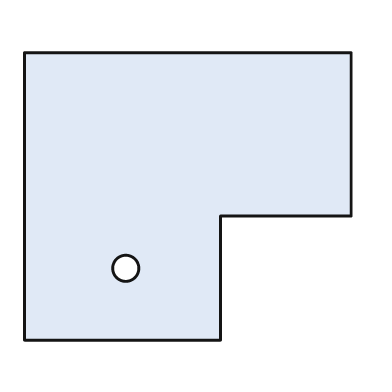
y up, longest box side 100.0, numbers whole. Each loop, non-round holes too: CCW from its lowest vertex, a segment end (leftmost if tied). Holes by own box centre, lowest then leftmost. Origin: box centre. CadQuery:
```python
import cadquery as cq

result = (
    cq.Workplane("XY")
    .moveTo(-50.0, -44.0)
    .lineTo(10.0, -44.0)
    .lineTo(10.0, -6.0)
    .lineTo(50.0, -6.0)
    .lineTo(50.0, 44.0)
    .lineTo(-50.0, 44.0)
    .close()
    .moveTo(-19.0, -22.0)
    .circle(4.0)
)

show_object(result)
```